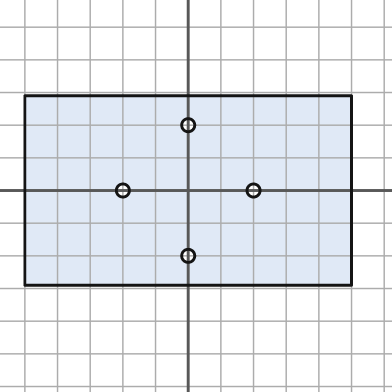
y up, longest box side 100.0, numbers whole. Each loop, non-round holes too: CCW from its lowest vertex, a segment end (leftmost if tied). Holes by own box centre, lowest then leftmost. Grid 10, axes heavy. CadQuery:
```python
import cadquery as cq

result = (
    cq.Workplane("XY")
    .moveTo(-50.0, -29.0)
    .lineTo(50.0, -29.0)
    .lineTo(50.0, 29.0)
    .lineTo(-50.0, 29.0)
    .close()
    .moveTo(0.0, -20.0)
    .circle(2.0)
    .moveTo(-20.0, 0.0)
    .circle(2.0)
    .moveTo(20.0, 0.0)
    .circle(2.0)
    .moveTo(0.0, 20.0)
    .circle(2.0)
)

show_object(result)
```